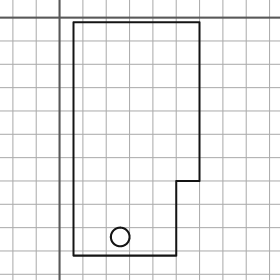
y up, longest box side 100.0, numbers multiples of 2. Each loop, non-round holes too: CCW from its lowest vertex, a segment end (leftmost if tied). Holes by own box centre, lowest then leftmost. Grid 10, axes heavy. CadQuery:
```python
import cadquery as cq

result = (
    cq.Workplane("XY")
    .moveTo(6.0, -102.0)
    .lineTo(50.0, -102.0)
    .lineTo(50.0, -70.0)
    .lineTo(60.0, -70.0)
    .lineTo(60.0, -2.0)
    .lineTo(6.0, -2.0)
    .close()
    .moveTo(26.0, -94.0)
    .circle(4.0)
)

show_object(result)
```